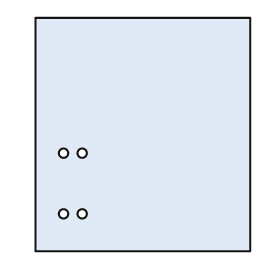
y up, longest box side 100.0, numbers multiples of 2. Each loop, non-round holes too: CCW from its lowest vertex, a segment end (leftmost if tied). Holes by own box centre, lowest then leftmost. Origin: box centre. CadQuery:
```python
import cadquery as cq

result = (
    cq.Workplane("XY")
    .moveTo(-46.0, -50.0)
    .lineTo(46.0, -50.0)
    .lineTo(46.0, 50.0)
    .lineTo(-46.0, 50.0)
    .close()
    .moveTo(-34.0, -34.0)
    .circle(2.0)
    .moveTo(-26.0, -34.0)
    .circle(2.0)
    .moveTo(-34.0, -8.0)
    .circle(2.0)
    .moveTo(-26.0, -8.0)
    .circle(2.0)
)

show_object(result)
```